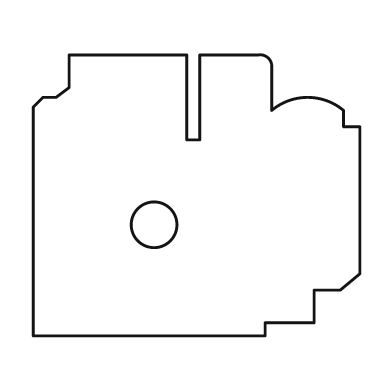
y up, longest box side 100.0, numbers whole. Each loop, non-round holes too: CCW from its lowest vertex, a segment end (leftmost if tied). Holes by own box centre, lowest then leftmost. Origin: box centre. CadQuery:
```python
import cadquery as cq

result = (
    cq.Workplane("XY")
    .moveTo(-50.0, -43.0)
    .lineTo(21.0, -43.0)
    .lineTo(21.0, -39.0)
    .lineTo(36.0, -39.0)
    .lineTo(36.0, -29.0)
    .lineTo(44.0, -29.0)
    .lineTo(50.0, -24.0)
    .lineTo(50.0, 21.0)
    .lineTo(45.0, 21.0)
    .lineTo(45.0, 26.0)
    .threePointArc((34.0, 30.0), (23.0, 26.0))
    .lineTo(23.0, 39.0)
    .threePointArc((22.0, 42.0), (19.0, 43.0))
    .lineTo(1.0, 43.0)
    .lineTo(1.0, 17.0)
    .lineTo(-3.0, 17.0)
    .lineTo(-3.0, 43.0)
    .lineTo(-39.0, 43.0)
    .lineTo(-39.0, 33.0)
    .lineTo(-43.0, 30.0)
    .lineTo(-47.0, 30.0)
    .lineTo(-50.0, 27.0)
    .close()
    .moveTo(-13.0, -9.0)
    .circle(7.0)
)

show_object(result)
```